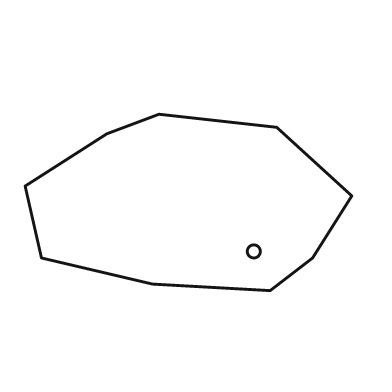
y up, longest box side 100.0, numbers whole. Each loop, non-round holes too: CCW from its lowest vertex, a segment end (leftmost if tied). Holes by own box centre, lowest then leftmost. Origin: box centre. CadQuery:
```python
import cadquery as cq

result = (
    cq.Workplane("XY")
    .moveTo(25.0, -27.0)
    .lineTo(38.0, -17.0)
    .lineTo(50.0, 2.0)
    .lineTo(27.0, 23.0)
    .lineTo(-9.0, 27.0)
    .lineTo(-25.0, 21.0)
    .lineTo(-50.0, 5.0)
    .lineTo(-45.0, -17.0)
    .lineTo(-11.0, -25.0)
    .close()
    .moveTo(20.0, -15.0)
    .circle(2.0)
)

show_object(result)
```